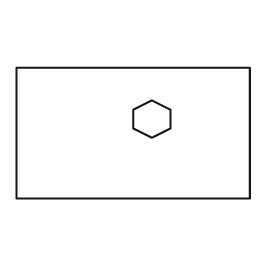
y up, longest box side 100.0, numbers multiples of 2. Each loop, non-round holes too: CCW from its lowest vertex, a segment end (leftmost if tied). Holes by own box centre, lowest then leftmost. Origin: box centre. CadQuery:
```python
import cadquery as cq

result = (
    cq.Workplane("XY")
    .moveTo(-50.0, -28.0)
    .lineTo(50.0, -28.0)
    .lineTo(50.0, 28.0)
    .lineTo(-50.0, 28.0)
    .close()
    .moveTo(8.0, -2.0)
    .lineTo(16.0, 2.0)
    .lineTo(16.0, 10.0)
    .lineTo(8.0, 14.0)
    .lineTo(0.0, 10.0)
    .lineTo(0.0, 2.0)
    .close()
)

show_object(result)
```